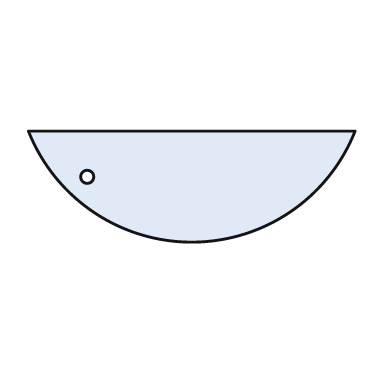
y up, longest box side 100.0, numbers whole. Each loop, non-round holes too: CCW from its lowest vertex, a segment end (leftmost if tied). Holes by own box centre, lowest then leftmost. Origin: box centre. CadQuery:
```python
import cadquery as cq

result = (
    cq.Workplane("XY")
    .moveTo(-50.0, 17.0)
    .threePointArc((0.0, -17.0), (50.0, 17.0))
    .close()
    .moveTo(-32.0, 3.0)
    .circle(2.0)
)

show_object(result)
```